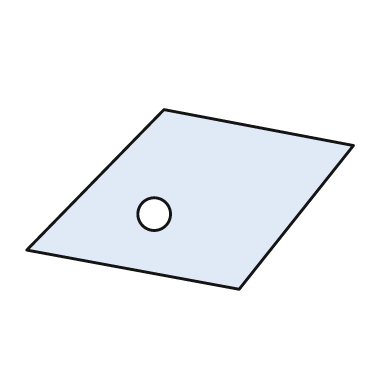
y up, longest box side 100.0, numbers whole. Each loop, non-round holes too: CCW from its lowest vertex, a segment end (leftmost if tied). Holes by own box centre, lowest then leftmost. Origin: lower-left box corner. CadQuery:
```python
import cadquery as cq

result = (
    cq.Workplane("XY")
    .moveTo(65.0, 0.0)
    .lineTo(100.0, 44.0)
    .lineTo(42.0, 55.0)
    .lineTo(0.0, 12.0)
    .close()
    .moveTo(39.0, 23.0)
    .circle(5.0)
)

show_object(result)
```